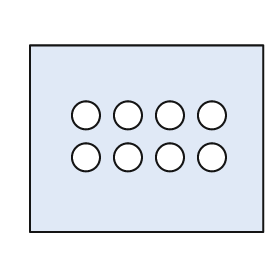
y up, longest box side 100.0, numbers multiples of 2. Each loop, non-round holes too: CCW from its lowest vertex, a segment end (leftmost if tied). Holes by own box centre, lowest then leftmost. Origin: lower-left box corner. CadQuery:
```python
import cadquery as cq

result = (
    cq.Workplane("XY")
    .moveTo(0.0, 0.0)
    .lineTo(100.0, 0.0)
    .lineTo(100.0, 80.0)
    .lineTo(0.0, 80.0)
    .close()
    .moveTo(24.0, 32.0)
    .circle(6.0)
    .moveTo(42.0, 32.0)
    .circle(6.0)
    .moveTo(60.0, 32.0)
    .circle(6.0)
    .moveTo(78.0, 32.0)
    .circle(6.0)
    .moveTo(24.0, 50.0)
    .circle(6.0)
    .moveTo(42.0, 50.0)
    .circle(6.0)
    .moveTo(60.0, 50.0)
    .circle(6.0)
    .moveTo(78.0, 50.0)
    .circle(6.0)
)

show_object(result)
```